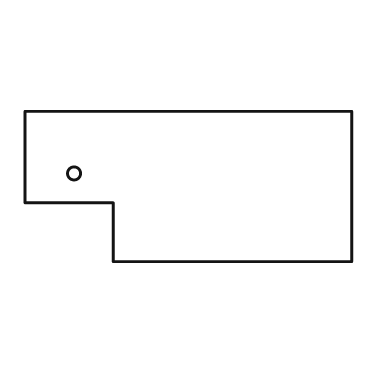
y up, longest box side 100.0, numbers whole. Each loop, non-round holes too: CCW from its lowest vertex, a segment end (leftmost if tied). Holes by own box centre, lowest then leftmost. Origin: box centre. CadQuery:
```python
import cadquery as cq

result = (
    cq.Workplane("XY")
    .moveTo(-23.0, -23.0)
    .lineTo(50.0, -23.0)
    .lineTo(50.0, 23.0)
    .lineTo(-50.0, 23.0)
    .lineTo(-50.0, -5.0)
    .lineTo(-23.0, -5.0)
    .close()
    .moveTo(-35.0, 4.0)
    .circle(2.0)
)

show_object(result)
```